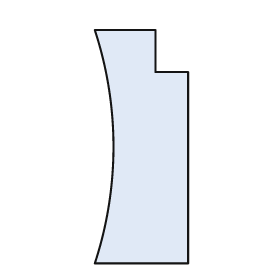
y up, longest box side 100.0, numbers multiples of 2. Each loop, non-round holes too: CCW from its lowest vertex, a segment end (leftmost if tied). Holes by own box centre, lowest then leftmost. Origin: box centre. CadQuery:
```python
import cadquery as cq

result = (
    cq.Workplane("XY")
    .moveTo(-20.0, -50.0)
    .lineTo(20.0, -50.0)
    .lineTo(20.0, 32.0)
    .lineTo(6.0, 32.0)
    .lineTo(6.0, 50.0)
    .lineTo(-20.0, 50.0)
    .threePointArc((-12.0, 0.0), (-20.0, -50.0))
    .close()
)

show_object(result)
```